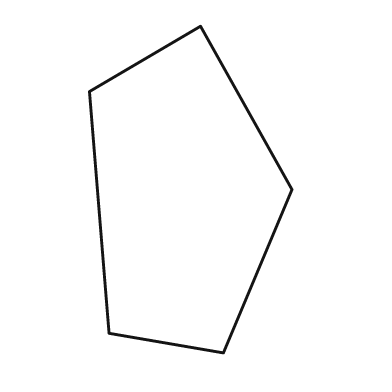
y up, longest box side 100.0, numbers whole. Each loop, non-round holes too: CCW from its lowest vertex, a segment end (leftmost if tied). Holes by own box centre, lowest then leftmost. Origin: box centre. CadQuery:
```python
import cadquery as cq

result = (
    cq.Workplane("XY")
    .moveTo(10.0, -50.0)
    .lineTo(31.0, 0.0)
    .lineTo(3.0, 50.0)
    .lineTo(-31.0, 30.0)
    .lineTo(-25.0, -44.0)
    .close()
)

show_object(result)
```